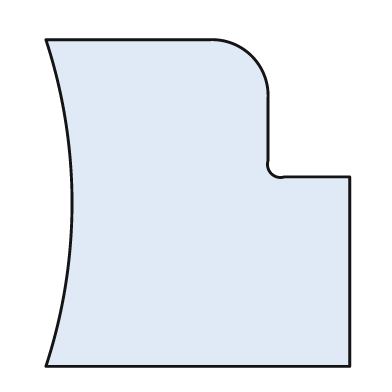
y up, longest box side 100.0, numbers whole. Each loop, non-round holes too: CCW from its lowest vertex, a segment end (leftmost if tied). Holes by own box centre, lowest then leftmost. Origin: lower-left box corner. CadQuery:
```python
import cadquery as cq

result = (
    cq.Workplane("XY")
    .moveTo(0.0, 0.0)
    .lineTo(93.0, 0.0)
    .lineTo(93.0, 58.0)
    .lineTo(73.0, 58.0)
    .threePointArc((69.0, 59.0), (68.0, 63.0))
    .lineTo(68.0, 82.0)
    .threePointArc((63.0, 95.0), (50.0, 100.0))
    .lineTo(0.0, 100.0)
    .threePointArc((8.0, 50.0), (0.0, 0.0))
    .close()
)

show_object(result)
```